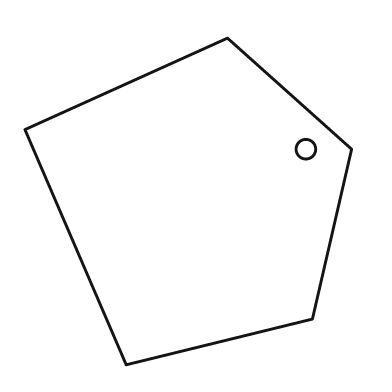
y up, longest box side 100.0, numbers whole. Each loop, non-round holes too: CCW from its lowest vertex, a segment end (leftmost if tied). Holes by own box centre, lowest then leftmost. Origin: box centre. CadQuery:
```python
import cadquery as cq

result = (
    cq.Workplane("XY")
    .moveTo(-19.0, -50.0)
    .lineTo(38.0, -36.0)
    .lineTo(50.0, 16.0)
    .lineTo(12.0, 50.0)
    .lineTo(-50.0, 22.0)
    .close()
    .moveTo(36.0, 16.0)
    .circle(3.0)
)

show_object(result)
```